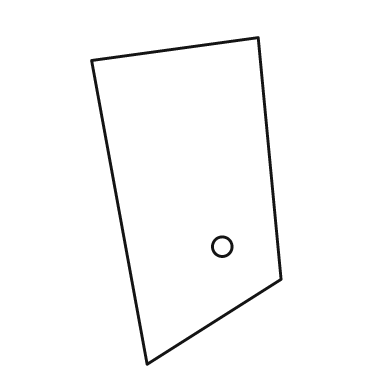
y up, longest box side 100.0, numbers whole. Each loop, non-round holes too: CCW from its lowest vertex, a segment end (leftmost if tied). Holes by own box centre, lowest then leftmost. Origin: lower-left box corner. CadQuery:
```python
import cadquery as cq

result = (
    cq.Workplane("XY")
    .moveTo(17.0, 0.0)
    .lineTo(58.0, 26.0)
    .lineTo(51.0, 100.0)
    .lineTo(0.0, 93.0)
    .close()
    .moveTo(40.0, 36.0)
    .circle(3.0)
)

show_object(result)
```